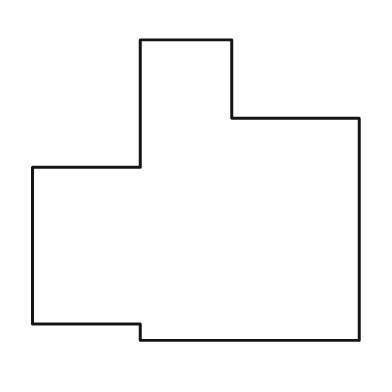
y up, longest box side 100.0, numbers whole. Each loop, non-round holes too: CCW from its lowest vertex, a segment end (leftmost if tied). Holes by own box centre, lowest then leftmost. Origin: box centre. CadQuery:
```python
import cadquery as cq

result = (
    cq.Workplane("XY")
    .moveTo(-17.0, -46.0)
    .lineTo(50.0, -46.0)
    .lineTo(50.0, 22.0)
    .lineTo(11.0, 22.0)
    .lineTo(11.0, 46.0)
    .lineTo(-17.0, 46.0)
    .lineTo(-17.0, 7.0)
    .lineTo(-50.0, 7.0)
    .lineTo(-50.0, -41.0)
    .lineTo(-17.0, -41.0)
    .close()
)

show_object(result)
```